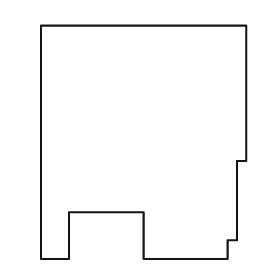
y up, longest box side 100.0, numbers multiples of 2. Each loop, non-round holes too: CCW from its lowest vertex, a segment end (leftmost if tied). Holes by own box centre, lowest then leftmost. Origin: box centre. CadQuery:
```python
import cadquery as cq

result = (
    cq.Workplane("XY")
    .moveTo(-44.0, -50.0)
    .lineTo(-32.0, -50.0)
    .lineTo(-32.0, -30.0)
    .lineTo(0.0, -30.0)
    .lineTo(0.0, -50.0)
    .lineTo(36.0, -50.0)
    .lineTo(36.0, -42.0)
    .lineTo(40.0, -42.0)
    .lineTo(40.0, -8.0)
    .lineTo(44.0, -8.0)
    .lineTo(44.0, 50.0)
    .lineTo(-44.0, 50.0)
    .close()
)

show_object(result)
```